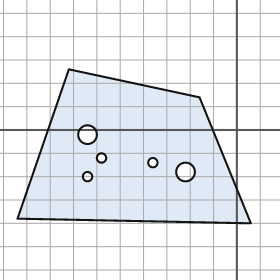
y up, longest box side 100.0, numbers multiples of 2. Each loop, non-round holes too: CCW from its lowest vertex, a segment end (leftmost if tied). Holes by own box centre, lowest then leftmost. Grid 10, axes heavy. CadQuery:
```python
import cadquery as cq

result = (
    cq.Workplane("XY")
    .moveTo(6.0, -40.0)
    .lineTo(-16.0, 14.0)
    .lineTo(-72.0, 26.0)
    .lineTo(-94.0, -38.0)
    .close()
    .moveTo(-64.0, -20.0)
    .circle(2.0)
    .moveTo(-22.0, -18.0)
    .circle(4.0)
    .moveTo(-36.0, -14.0)
    .circle(2.0)
    .moveTo(-58.0, -12.0)
    .circle(2.0)
    .moveTo(-64.0, -2.0)
    .circle(4.0)
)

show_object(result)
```